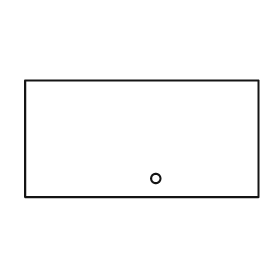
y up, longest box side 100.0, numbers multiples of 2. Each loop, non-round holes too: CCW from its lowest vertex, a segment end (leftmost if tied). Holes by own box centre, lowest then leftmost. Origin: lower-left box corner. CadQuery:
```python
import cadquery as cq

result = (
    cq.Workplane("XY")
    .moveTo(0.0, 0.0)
    .lineTo(100.0, 0.0)
    .lineTo(100.0, 50.0)
    .lineTo(0.0, 50.0)
    .close()
    .moveTo(56.0, 8.0)
    .circle(2.0)
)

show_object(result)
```